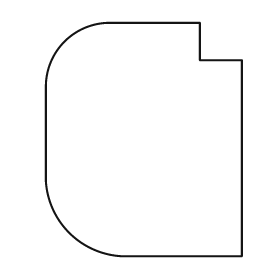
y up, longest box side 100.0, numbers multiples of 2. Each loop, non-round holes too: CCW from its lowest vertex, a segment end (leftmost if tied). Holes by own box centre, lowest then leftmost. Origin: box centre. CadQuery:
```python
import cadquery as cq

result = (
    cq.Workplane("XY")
    .moveTo(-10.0, -50.0)
    .lineTo(42.0, -50.0)
    .lineTo(42.0, 34.0)
    .lineTo(24.0, 34.0)
    .lineTo(24.0, 50.0)
    .lineTo(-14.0, 50.0)
    .threePointArc((-34.0, 42.0), (-42.0, 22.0))
    .lineTo(-42.0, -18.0)
    .threePointArc((-32.0, -40.0), (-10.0, -50.0))
    .close()
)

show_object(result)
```